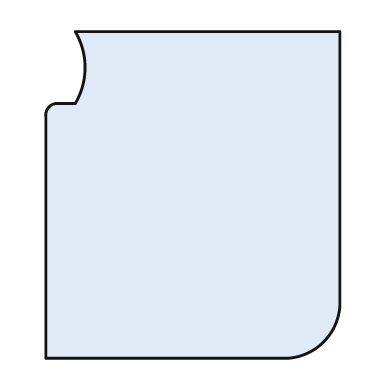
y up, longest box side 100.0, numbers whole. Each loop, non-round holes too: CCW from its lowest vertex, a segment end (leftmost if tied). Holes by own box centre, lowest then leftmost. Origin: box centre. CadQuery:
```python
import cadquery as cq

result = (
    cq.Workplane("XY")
    .moveTo(-45.0, -50.0)
    .lineTo(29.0, -50.0)
    .threePointArc((40.0, -45.0), (45.0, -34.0))
    .lineTo(45.0, 50.0)
    .lineTo(-36.0, 50.0)
    .threePointArc((-33.0, 39.0), (-36.0, 28.0))
    .lineTo(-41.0, 28.0)
    .threePointArc((-44.0, 27.0), (-45.0, 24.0))
    .close()
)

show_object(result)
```